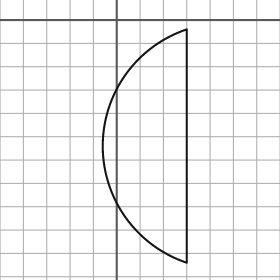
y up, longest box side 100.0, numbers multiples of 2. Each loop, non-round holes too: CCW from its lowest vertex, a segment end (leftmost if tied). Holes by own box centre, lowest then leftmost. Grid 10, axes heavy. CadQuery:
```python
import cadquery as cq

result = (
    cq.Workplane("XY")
    .moveTo(30.0, -104.0)
    .lineTo(30.0, -4.0)
    .threePointArc((-6.0, -54.0), (30.0, -104.0))
    .close()
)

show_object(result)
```